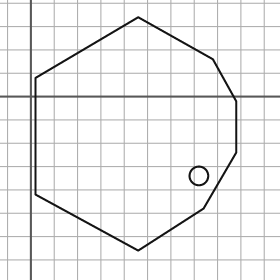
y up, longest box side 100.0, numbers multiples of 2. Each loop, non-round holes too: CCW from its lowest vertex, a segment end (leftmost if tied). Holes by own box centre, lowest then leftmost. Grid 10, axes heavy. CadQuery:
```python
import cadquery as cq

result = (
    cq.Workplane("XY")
    .moveTo(46.0, -66.0)
    .lineTo(74.0, -48.0)
    .lineTo(88.0, -24.0)
    .lineTo(88.0, -2.0)
    .lineTo(78.0, 16.0)
    .lineTo(46.0, 34.0)
    .lineTo(2.0, 8.0)
    .lineTo(2.0, -42.0)
    .close()
    .moveTo(72.0, -34.0)
    .circle(4.0)
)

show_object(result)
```